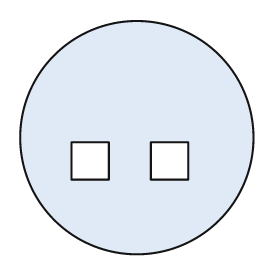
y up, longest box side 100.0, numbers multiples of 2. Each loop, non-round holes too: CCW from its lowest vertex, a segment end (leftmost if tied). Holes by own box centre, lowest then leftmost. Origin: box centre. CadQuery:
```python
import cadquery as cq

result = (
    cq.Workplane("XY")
    .moveTo(0.0, 0.0)
    .circle(50.0)
    .moveTo(-28.0, -18.0)
    .lineTo(-12.0, -18.0)
    .lineTo(-12.0, -2.0)
    .lineTo(-28.0, -2.0)
    .close()
    .moveTo(6.0, -18.0)
    .lineTo(22.0, -18.0)
    .lineTo(22.0, -2.0)
    .lineTo(6.0, -2.0)
    .close()
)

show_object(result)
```